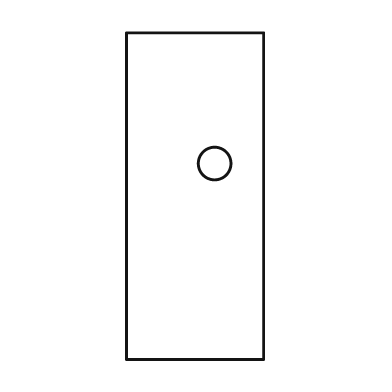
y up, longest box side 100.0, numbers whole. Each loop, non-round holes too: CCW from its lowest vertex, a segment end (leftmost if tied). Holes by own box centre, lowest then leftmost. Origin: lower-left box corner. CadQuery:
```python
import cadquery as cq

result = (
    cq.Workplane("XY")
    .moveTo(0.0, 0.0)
    .lineTo(42.0, 0.0)
    .lineTo(42.0, 100.0)
    .lineTo(0.0, 100.0)
    .close()
    .moveTo(27.0, 60.0)
    .circle(5.0)
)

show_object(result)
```